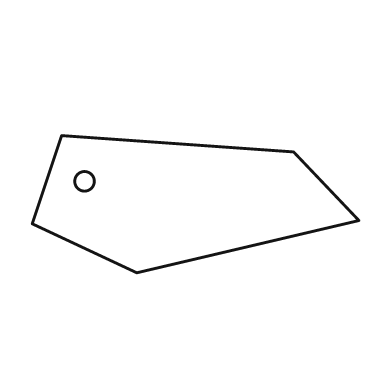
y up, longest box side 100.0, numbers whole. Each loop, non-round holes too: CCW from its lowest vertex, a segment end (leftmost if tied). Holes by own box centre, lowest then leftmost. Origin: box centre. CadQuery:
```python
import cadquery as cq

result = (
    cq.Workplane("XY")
    .moveTo(-18.0, -21.0)
    .lineTo(50.0, -5.0)
    .lineTo(30.0, 16.0)
    .lineTo(-41.0, 21.0)
    .lineTo(-50.0, -6.0)
    .close()
    .moveTo(-34.0, 7.0)
    .circle(3.0)
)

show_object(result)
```